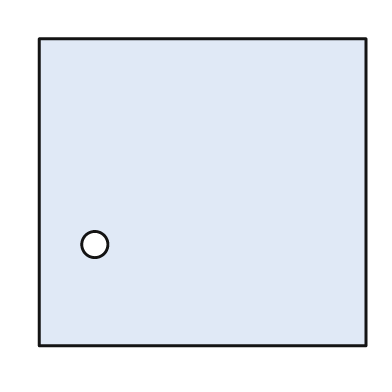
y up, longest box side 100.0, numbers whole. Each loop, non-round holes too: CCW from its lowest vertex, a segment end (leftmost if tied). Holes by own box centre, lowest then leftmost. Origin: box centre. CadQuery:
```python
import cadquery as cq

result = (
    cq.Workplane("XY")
    .moveTo(-50.0, -47.0)
    .lineTo(50.0, -47.0)
    .lineTo(50.0, 47.0)
    .lineTo(-50.0, 47.0)
    .close()
    .moveTo(-33.0, -16.0)
    .circle(4.0)
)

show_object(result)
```